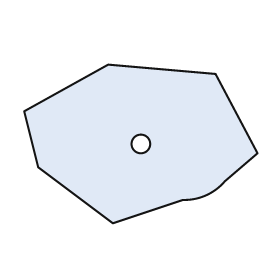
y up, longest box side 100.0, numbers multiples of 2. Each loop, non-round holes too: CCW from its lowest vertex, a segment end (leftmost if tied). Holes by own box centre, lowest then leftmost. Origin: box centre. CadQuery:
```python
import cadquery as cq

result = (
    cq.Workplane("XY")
    .moveTo(-12.0, -34.0)
    .lineTo(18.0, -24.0)
    .threePointArc((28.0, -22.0), (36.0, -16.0))
    .lineTo(50.0, -4.0)
    .lineTo(32.0, 30.0)
    .lineTo(-14.0, 34.0)
    .lineTo(-50.0, 14.0)
    .lineTo(-44.0, -10.0)
    .close()
    .moveTo(0.0, 0.0)
    .circle(4.0)
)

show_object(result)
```